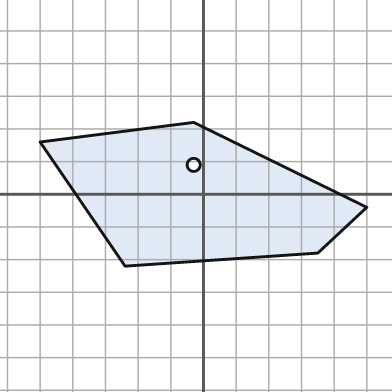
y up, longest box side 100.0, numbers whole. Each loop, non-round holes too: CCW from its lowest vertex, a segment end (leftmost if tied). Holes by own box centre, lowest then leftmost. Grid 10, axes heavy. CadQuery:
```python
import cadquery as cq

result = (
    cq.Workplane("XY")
    .moveTo(-24.0, -22.0)
    .lineTo(35.0, -18.0)
    .lineTo(50.0, -4.0)
    .lineTo(-3.0, 22.0)
    .lineTo(-50.0, 16.0)
    .close()
    .moveTo(-3.0, 9.0)
    .circle(2.0)
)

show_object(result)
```